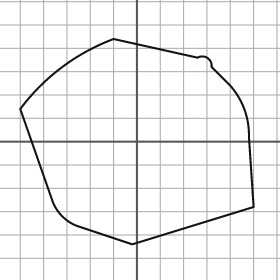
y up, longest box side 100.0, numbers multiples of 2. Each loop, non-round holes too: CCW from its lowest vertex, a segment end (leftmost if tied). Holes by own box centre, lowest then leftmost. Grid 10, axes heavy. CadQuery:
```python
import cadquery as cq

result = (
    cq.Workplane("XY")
    .moveTo(-2.0, -44.0)
    .lineTo(50.0, -28.0)
    .lineTo(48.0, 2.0)
    .threePointArc((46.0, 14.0), (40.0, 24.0))
    .lineTo(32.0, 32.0)
    .threePointArc((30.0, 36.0), (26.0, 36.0))
    .lineTo(-10.0, 44.0)
    .threePointArc((-32.0, 32.0), (-50.0, 14.0))
    .lineTo(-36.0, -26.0)
    .threePointArc((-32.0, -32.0), (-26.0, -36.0))
    .close()
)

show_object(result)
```